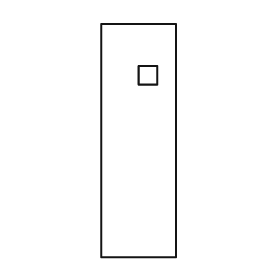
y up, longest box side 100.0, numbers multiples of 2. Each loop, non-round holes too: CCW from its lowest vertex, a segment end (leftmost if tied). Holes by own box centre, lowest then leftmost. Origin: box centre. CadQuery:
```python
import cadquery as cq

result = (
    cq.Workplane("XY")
    .moveTo(-16.0, -50.0)
    .lineTo(16.0, -50.0)
    .lineTo(16.0, 50.0)
    .lineTo(-16.0, 50.0)
    .close()
    .moveTo(0.0, 24.0)
    .lineTo(8.0, 24.0)
    .lineTo(8.0, 32.0)
    .lineTo(0.0, 32.0)
    .close()
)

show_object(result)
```